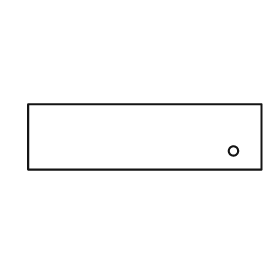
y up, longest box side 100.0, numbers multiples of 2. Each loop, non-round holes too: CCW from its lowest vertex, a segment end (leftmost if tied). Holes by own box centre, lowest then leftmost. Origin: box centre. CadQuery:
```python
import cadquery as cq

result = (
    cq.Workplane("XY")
    .moveTo(-50.0, -14.0)
    .lineTo(50.0, -14.0)
    .lineTo(50.0, 14.0)
    .lineTo(-50.0, 14.0)
    .close()
    .moveTo(38.0, -6.0)
    .circle(2.0)
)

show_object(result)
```